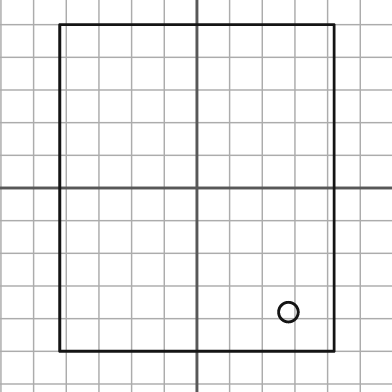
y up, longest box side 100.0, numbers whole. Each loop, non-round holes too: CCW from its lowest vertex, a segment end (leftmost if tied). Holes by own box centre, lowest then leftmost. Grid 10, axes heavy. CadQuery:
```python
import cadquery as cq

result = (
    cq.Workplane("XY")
    .moveTo(-42.0, -50.0)
    .lineTo(42.0, -50.0)
    .lineTo(42.0, 50.0)
    .lineTo(-42.0, 50.0)
    .close()
    .moveTo(28.0, -38.0)
    .circle(3.0)
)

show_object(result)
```